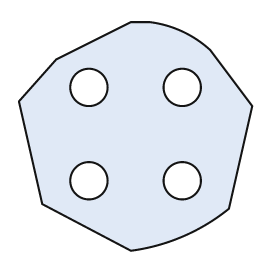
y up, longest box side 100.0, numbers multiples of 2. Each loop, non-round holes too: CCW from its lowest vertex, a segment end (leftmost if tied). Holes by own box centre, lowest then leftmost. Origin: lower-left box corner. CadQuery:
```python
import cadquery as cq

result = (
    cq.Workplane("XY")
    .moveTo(48.0, 0.0)
    .threePointArc((70.0, 6.0), (90.0, 18.0))
    .lineTo(100.0, 62.0)
    .lineTo(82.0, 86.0)
    .threePointArc((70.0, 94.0), (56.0, 98.0))
    .lineTo(48.0, 98.0)
    .lineTo(16.0, 82.0)
    .lineTo(0.0, 64.0)
    .lineTo(10.0, 20.0)
    .close()
    .moveTo(30.0, 30.0)
    .circle(8.0)
    .moveTo(70.0, 30.0)
    .circle(8.0)
    .moveTo(30.0, 70.0)
    .circle(8.0)
    .moveTo(70.0, 70.0)
    .circle(8.0)
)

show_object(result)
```